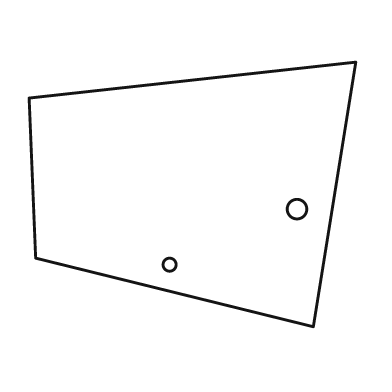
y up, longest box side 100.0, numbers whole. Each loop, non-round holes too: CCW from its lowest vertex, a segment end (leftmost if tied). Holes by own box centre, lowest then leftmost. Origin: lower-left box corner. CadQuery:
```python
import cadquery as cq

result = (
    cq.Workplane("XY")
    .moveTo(87.0, 0.0)
    .lineTo(100.0, 81.0)
    .lineTo(0.0, 70.0)
    .lineTo(2.0, 21.0)
    .close()
    .moveTo(43.0, 19.0)
    .circle(2.0)
    .moveTo(82.0, 36.0)
    .circle(3.0)
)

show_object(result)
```